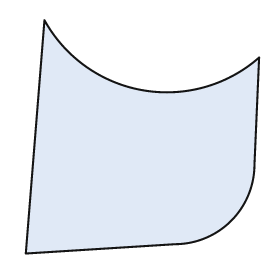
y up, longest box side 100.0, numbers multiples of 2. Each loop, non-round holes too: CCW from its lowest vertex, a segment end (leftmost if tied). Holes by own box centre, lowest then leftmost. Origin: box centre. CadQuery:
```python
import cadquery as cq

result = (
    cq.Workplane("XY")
    .moveTo(-50.0, -50.0)
    .lineTo(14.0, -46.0)
    .threePointArc((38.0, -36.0), (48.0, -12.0))
    .lineTo(50.0, 34.0)
    .threePointArc((0.0, 20.0), (-42.0, 50.0))
    .close()
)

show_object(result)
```